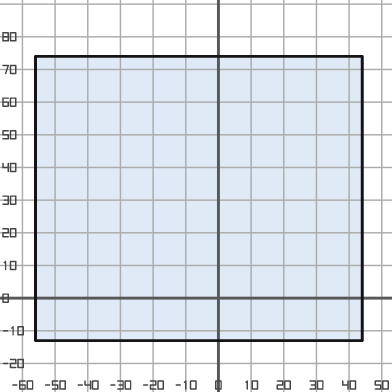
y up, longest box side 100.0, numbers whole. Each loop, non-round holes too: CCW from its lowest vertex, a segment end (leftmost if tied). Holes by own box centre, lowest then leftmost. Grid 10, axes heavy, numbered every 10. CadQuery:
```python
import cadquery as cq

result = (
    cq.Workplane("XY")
    .moveTo(-56.0, -13.0)
    .lineTo(44.0, -13.0)
    .lineTo(44.0, 74.0)
    .lineTo(-56.0, 74.0)
    .close()
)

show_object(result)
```